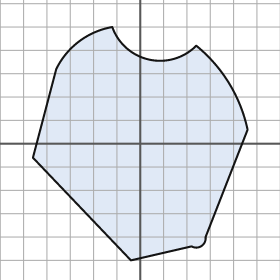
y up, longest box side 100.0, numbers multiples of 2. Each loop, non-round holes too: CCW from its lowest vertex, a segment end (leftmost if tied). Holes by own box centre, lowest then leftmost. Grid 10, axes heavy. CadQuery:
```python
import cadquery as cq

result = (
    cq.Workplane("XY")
    .moveTo(-4.0, -50.0)
    .lineTo(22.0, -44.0)
    .threePointArc((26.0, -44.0), (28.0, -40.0))
    .lineTo(46.0, 6.0)
    .threePointArc((38.0, 26.0), (24.0, 42.0))
    .threePointArc((4.0, 36.0), (-12.0, 50.0))
    .threePointArc((-26.0, 44.0), (-36.0, 32.0))
    .lineTo(-46.0, -6.0)
    .close()
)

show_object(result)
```